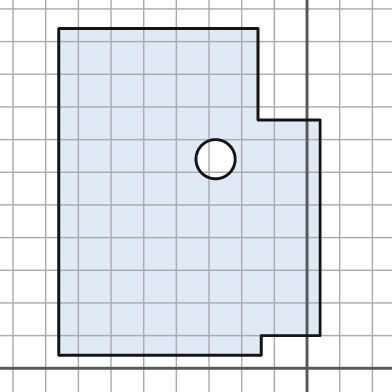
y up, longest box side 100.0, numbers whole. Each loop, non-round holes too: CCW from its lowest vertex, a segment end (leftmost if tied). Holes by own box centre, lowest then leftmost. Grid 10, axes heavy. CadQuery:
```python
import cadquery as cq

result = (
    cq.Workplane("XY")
    .moveTo(-76.0, 4.0)
    .lineTo(-14.0, 4.0)
    .lineTo(-14.0, 10.0)
    .lineTo(4.0, 10.0)
    .lineTo(4.0, 76.0)
    .lineTo(-15.0, 76.0)
    .lineTo(-15.0, 104.0)
    .lineTo(-76.0, 104.0)
    .close()
    .moveTo(-28.0, 64.0)
    .circle(6.0)
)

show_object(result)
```